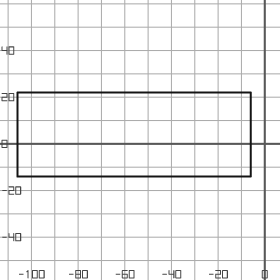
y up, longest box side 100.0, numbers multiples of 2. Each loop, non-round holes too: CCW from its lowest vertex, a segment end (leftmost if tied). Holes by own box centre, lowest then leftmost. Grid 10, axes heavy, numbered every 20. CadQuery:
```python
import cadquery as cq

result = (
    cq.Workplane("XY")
    .moveTo(-106.0, -14.0)
    .lineTo(-6.0, -14.0)
    .lineTo(-6.0, 22.0)
    .lineTo(-106.0, 22.0)
    .close()
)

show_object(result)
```